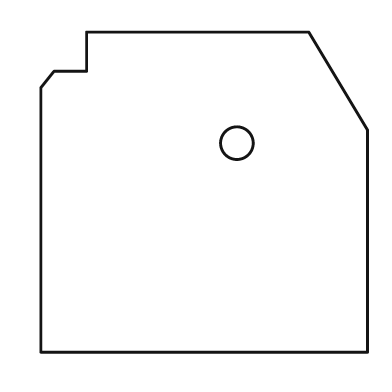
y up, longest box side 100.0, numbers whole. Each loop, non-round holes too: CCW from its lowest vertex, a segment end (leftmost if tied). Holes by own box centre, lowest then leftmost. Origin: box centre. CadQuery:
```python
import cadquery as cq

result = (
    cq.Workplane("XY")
    .moveTo(-50.0, -49.0)
    .lineTo(50.0, -49.0)
    .lineTo(50.0, 19.0)
    .lineTo(32.0, 49.0)
    .lineTo(-36.0, 49.0)
    .lineTo(-36.0, 37.0)
    .lineTo(-46.0, 37.0)
    .lineTo(-50.0, 32.0)
    .close()
    .moveTo(10.0, 15.0)
    .circle(5.0)
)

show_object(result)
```